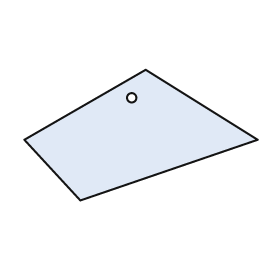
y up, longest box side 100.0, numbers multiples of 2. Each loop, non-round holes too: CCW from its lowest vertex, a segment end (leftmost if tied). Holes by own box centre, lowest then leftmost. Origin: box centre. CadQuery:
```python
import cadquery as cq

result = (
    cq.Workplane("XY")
    .moveTo(-26.0, -28.0)
    .lineTo(50.0, -2.0)
    .lineTo(2.0, 28.0)
    .lineTo(-50.0, -2.0)
    .close()
    .moveTo(-4.0, 16.0)
    .circle(2.0)
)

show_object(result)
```